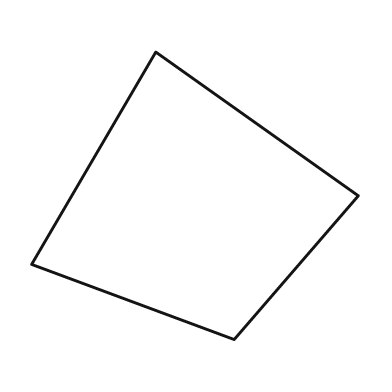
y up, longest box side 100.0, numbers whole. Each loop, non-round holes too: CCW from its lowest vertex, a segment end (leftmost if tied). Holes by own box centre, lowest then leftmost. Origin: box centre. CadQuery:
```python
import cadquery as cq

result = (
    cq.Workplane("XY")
    .moveTo(12.0, -44.0)
    .lineTo(50.0, 0.0)
    .lineTo(-12.0, 44.0)
    .lineTo(-50.0, -21.0)
    .close()
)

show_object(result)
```